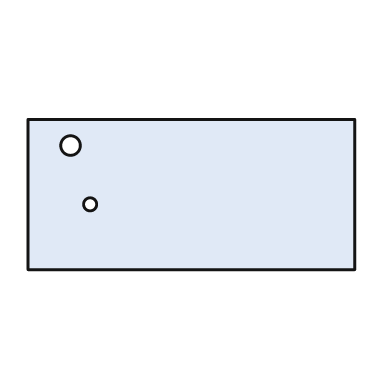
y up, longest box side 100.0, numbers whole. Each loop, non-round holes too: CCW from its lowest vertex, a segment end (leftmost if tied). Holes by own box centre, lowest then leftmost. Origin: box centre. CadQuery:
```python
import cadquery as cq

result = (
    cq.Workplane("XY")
    .moveTo(-50.0, -23.0)
    .lineTo(50.0, -23.0)
    .lineTo(50.0, 23.0)
    .lineTo(-50.0, 23.0)
    .close()
    .moveTo(-31.0, -3.0)
    .circle(2.0)
    .moveTo(-37.0, 15.0)
    .circle(3.0)
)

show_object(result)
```